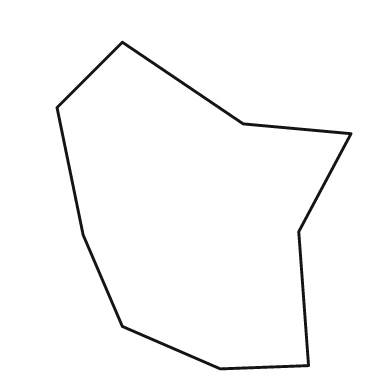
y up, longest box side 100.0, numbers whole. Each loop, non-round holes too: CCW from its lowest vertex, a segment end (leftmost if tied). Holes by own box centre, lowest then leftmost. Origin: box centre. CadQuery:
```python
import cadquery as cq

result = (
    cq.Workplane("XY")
    .moveTo(5.0, -50.0)
    .lineTo(32.0, -49.0)
    .lineTo(29.0, -8.0)
    .lineTo(45.0, 22.0)
    .lineTo(12.0, 25.0)
    .lineTo(-25.0, 50.0)
    .lineTo(-45.0, 30.0)
    .lineTo(-37.0, -9.0)
    .lineTo(-25.0, -37.0)
    .close()
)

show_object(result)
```